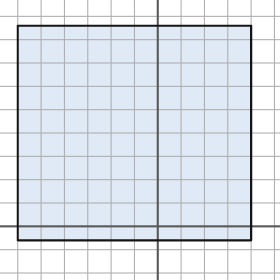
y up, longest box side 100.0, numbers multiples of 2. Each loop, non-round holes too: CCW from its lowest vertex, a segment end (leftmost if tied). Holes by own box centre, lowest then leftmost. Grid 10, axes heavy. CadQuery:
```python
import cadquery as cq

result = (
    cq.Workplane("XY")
    .moveTo(-60.0, -6.0)
    .lineTo(40.0, -6.0)
    .lineTo(40.0, 86.0)
    .lineTo(-60.0, 86.0)
    .close()
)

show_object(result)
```